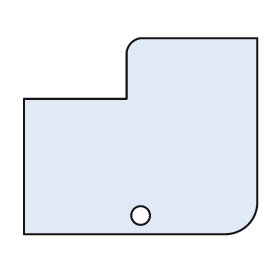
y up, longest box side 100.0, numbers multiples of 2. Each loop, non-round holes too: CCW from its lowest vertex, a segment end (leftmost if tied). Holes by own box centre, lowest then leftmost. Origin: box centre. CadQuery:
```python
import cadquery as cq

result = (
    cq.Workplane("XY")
    .moveTo(-50.0, -42.0)
    .lineTo(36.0, -42.0)
    .threePointArc((46.0, -38.0), (50.0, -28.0))
    .lineTo(50.0, 42.0)
    .lineTo(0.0, 42.0)
    .threePointArc((-4.0, 40.0), (-6.0, 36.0))
    .lineTo(-6.0, 16.0)
    .lineTo(-50.0, 16.0)
    .close()
    .moveTo(0.0, -34.0)
    .circle(4.0)
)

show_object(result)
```